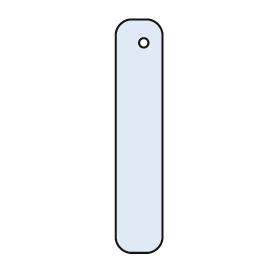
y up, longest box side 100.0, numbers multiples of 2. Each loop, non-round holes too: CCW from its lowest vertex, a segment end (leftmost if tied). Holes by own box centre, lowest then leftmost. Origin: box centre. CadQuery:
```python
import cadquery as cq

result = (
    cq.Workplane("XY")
    .moveTo(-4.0, -50.0)
    .lineTo(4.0, -50.0)
    .threePointArc((8.0, -48.0), (10.0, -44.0))
    .lineTo(10.0, 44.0)
    .threePointArc((8.0, 48.0), (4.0, 50.0))
    .lineTo(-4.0, 50.0)
    .threePointArc((-8.0, 48.0), (-10.0, 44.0))
    .lineTo(-10.0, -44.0)
    .threePointArc((-8.0, -48.0), (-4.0, -50.0))
    .close()
    .moveTo(2.0, 40.0)
    .circle(2.0)
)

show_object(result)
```